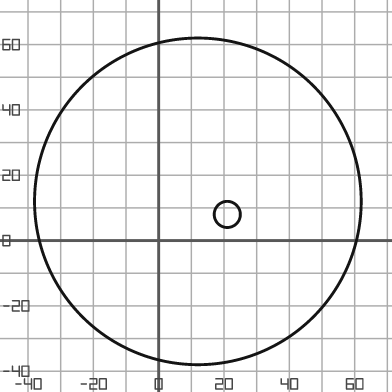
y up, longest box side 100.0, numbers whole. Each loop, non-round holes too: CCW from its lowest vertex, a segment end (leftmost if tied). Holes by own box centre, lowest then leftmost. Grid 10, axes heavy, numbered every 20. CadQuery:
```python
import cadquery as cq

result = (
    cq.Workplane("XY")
    .moveTo(12.0, 12.0)
    .circle(50.0)
    .moveTo(21.0, 8.0)
    .circle(4.0)
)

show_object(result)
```